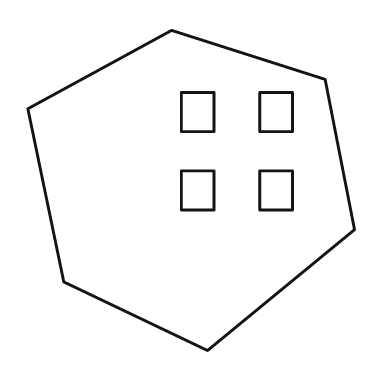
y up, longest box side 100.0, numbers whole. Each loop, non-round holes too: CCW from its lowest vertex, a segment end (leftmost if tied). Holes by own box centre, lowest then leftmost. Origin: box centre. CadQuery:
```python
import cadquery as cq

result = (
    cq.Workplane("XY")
    .moveTo(5.0, -49.0)
    .lineTo(50.0, -12.0)
    .lineTo(41.0, 34.0)
    .lineTo(-6.0, 49.0)
    .lineTo(-50.0, 25.0)
    .lineTo(-39.0, -28.0)
    .close()
    .moveTo(-3.0, -6.0)
    .lineTo(7.0, -6.0)
    .lineTo(7.0, 6.0)
    .lineTo(-3.0, 6.0)
    .close()
    .moveTo(21.0, -6.0)
    .lineTo(31.0, -6.0)
    .lineTo(31.0, 6.0)
    .lineTo(21.0, 6.0)
    .close()
    .moveTo(-3.0, 18.0)
    .lineTo(7.0, 18.0)
    .lineTo(7.0, 30.0)
    .lineTo(-3.0, 30.0)
    .close()
    .moveTo(21.0, 18.0)
    .lineTo(31.0, 18.0)
    .lineTo(31.0, 30.0)
    .lineTo(21.0, 30.0)
    .close()
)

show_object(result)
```